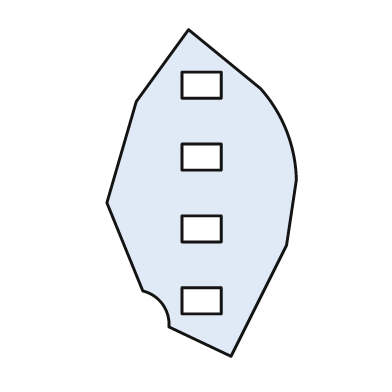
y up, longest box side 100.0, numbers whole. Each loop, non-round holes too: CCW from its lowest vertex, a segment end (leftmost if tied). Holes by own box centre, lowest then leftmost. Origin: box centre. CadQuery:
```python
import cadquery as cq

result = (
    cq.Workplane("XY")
    .moveTo(9.0, -50.0)
    .lineTo(26.0, -16.0)
    .lineTo(29.0, 4.0)
    .threePointArc((26.0, 19.0), (18.0, 32.0))
    .lineTo(-4.0, 50.0)
    .lineTo(-20.0, 28.0)
    .lineTo(-29.0, -3.0)
    .lineTo(-18.0, -30.0)
    .threePointArc((-12.0, -34.0), (-10.0, -41.0))
    .close()
    .moveTo(-6.0, -37.0)
    .lineTo(6.0, -37.0)
    .lineTo(6.0, -29.0)
    .lineTo(-6.0, -29.0)
    .close()
    .moveTo(-6.0, -15.0)
    .lineTo(6.0, -15.0)
    .lineTo(6.0, -7.0)
    .lineTo(-6.0, -7.0)
    .close()
    .moveTo(-6.0, 7.0)
    .lineTo(6.0, 7.0)
    .lineTo(6.0, 15.0)
    .lineTo(-6.0, 15.0)
    .close()
    .moveTo(-6.0, 29.0)
    .lineTo(6.0, 29.0)
    .lineTo(6.0, 37.0)
    .lineTo(-6.0, 37.0)
    .close()
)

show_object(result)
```